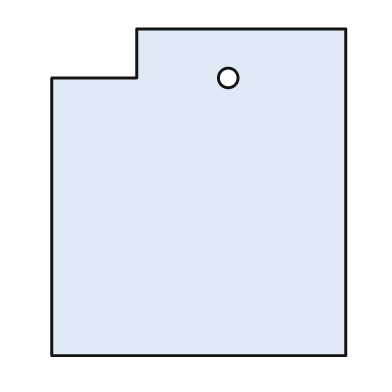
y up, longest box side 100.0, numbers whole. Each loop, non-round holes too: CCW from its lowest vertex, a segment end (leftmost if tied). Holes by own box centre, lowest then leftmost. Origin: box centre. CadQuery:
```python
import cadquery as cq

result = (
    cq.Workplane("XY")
    .moveTo(-45.0, -50.0)
    .lineTo(45.0, -50.0)
    .lineTo(45.0, 50.0)
    .lineTo(-19.0, 50.0)
    .lineTo(-19.0, 35.0)
    .lineTo(-45.0, 35.0)
    .close()
    .moveTo(9.0, 35.0)
    .circle(3.0)
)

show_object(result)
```